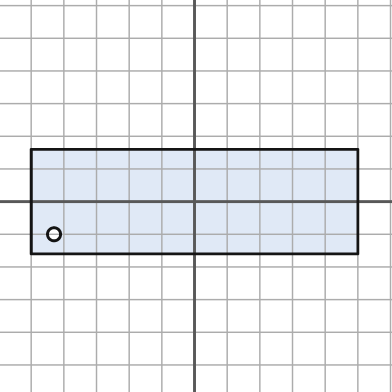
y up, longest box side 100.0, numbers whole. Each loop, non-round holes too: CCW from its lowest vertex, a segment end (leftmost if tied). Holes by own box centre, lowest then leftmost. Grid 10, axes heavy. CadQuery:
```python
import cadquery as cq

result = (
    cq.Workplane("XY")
    .moveTo(-50.0, -16.0)
    .lineTo(50.0, -16.0)
    .lineTo(50.0, 16.0)
    .lineTo(-50.0, 16.0)
    .close()
    .moveTo(-43.0, -10.0)
    .circle(2.0)
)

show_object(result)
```